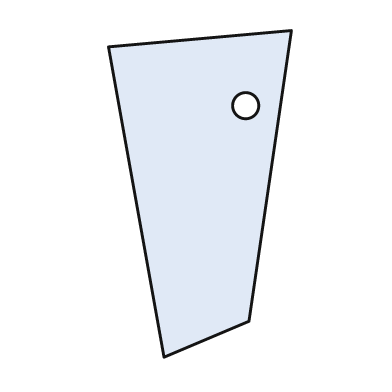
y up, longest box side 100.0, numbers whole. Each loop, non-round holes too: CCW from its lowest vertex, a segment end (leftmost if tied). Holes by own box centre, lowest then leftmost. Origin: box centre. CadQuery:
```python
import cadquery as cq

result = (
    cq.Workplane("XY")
    .moveTo(-11.0, -50.0)
    .lineTo(15.0, -39.0)
    .lineTo(28.0, 50.0)
    .lineTo(-28.0, 45.0)
    .close()
    .moveTo(14.0, 27.0)
    .circle(4.0)
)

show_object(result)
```